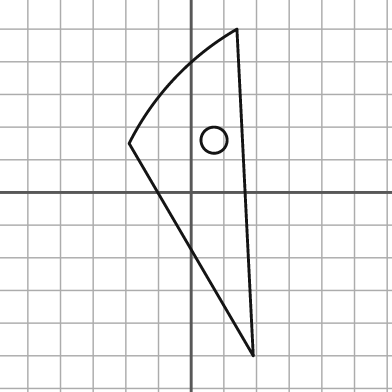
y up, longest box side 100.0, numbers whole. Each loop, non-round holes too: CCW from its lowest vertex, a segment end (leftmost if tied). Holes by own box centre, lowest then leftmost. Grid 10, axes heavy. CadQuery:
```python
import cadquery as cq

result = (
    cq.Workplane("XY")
    .moveTo(19.0, -50.0)
    .lineTo(14.0, 50.0)
    .threePointArc((-5.0, 35.0), (-19.0, 15.0))
    .close()
    .moveTo(7.0, 16.0)
    .circle(4.0)
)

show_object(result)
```